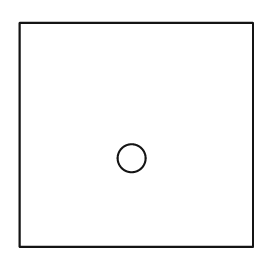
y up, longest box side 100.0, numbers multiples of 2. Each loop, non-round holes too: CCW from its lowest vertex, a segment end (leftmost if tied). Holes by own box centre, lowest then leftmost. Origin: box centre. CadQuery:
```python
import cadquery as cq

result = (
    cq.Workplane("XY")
    .moveTo(-50.0, -48.0)
    .lineTo(50.0, -48.0)
    .lineTo(50.0, 48.0)
    .lineTo(-50.0, 48.0)
    .close()
    .moveTo(-2.0, -10.0)
    .circle(6.0)
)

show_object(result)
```